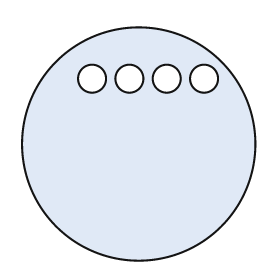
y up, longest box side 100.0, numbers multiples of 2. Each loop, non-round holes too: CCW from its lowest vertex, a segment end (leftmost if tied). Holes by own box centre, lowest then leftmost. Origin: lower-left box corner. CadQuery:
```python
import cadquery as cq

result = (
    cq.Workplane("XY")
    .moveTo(50.0, 50.0)
    .circle(50.0)
    .moveTo(30.0, 78.0)
    .circle(6.0)
    .moveTo(46.0, 78.0)
    .circle(6.0)
    .moveTo(62.0, 78.0)
    .circle(6.0)
    .moveTo(78.0, 78.0)
    .circle(6.0)
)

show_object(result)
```